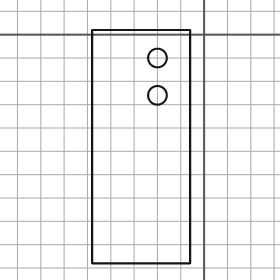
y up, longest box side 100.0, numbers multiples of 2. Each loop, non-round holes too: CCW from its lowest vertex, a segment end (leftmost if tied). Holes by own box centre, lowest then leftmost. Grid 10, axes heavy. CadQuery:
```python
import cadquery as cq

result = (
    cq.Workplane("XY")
    .moveTo(-48.0, -98.0)
    .lineTo(-6.0, -98.0)
    .lineTo(-6.0, 2.0)
    .lineTo(-48.0, 2.0)
    .close()
    .moveTo(-20.0, -26.0)
    .circle(4.0)
    .moveTo(-20.0, -10.0)
    .circle(4.0)
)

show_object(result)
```